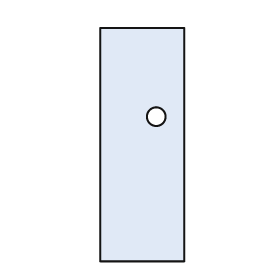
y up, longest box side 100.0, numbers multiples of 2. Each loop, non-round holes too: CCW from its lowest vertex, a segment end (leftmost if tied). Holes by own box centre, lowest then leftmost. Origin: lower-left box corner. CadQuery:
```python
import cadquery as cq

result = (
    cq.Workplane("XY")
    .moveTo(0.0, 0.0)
    .lineTo(36.0, 0.0)
    .lineTo(36.0, 100.0)
    .lineTo(0.0, 100.0)
    .close()
    .moveTo(24.0, 62.0)
    .circle(4.0)
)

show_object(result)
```